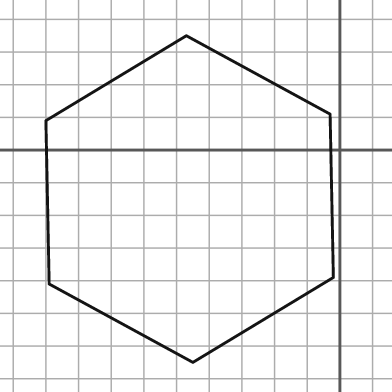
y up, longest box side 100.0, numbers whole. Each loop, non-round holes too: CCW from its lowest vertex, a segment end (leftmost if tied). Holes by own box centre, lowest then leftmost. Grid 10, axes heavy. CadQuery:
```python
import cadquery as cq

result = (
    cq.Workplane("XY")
    .moveTo(-45.0, -65.0)
    .lineTo(-2.0, -39.0)
    .lineTo(-3.0, 11.0)
    .lineTo(-47.0, 35.0)
    .lineTo(-90.0, 9.0)
    .lineTo(-89.0, -41.0)
    .close()
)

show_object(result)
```